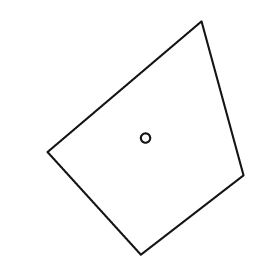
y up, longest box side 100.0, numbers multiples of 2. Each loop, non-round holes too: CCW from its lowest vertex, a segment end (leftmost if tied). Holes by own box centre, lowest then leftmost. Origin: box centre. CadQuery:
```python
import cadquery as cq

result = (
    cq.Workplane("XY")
    .moveTo(-2.0, -50.0)
    .lineTo(42.0, -16.0)
    .lineTo(24.0, 50.0)
    .lineTo(-42.0, -6.0)
    .close()
    .moveTo(0.0, 0.0)
    .circle(2.0)
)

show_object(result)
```